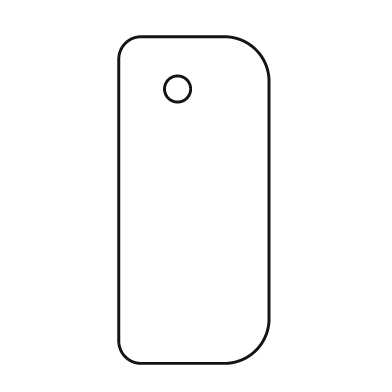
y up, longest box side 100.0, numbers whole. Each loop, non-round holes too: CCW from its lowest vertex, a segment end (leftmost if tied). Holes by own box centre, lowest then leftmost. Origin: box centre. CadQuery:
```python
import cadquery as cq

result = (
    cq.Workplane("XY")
    .moveTo(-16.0, -50.0)
    .lineTo(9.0, -50.0)
    .threePointArc((19.0, -46.0), (23.0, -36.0))
    .lineTo(23.0, 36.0)
    .threePointArc((19.0, 46.0), (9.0, 50.0))
    .lineTo(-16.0, 50.0)
    .threePointArc((-21.0, 48.0), (-23.0, 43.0))
    .lineTo(-23.0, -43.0)
    .threePointArc((-21.0, -48.0), (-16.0, -50.0))
    .close()
    .moveTo(-5.0, 34.0)
    .circle(4.0)
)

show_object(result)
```